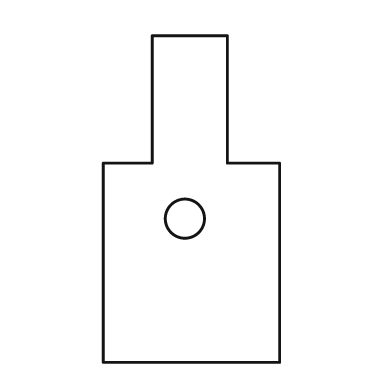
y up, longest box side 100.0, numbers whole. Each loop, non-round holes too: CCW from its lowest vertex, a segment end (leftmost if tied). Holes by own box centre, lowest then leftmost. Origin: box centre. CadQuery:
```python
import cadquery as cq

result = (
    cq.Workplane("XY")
    .moveTo(-27.0, -50.0)
    .lineTo(27.0, -50.0)
    .lineTo(27.0, 11.0)
    .lineTo(11.0, 11.0)
    .lineTo(11.0, 50.0)
    .lineTo(-12.0, 50.0)
    .lineTo(-12.0, 11.0)
    .lineTo(-27.0, 11.0)
    .close()
    .moveTo(-2.0, -6.0)
    .circle(6.0)
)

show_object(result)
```